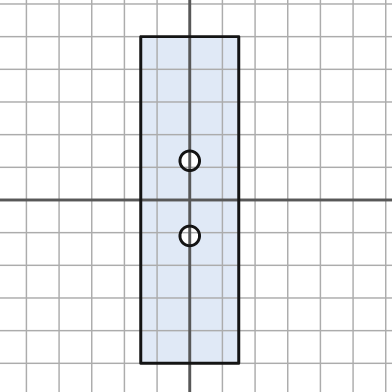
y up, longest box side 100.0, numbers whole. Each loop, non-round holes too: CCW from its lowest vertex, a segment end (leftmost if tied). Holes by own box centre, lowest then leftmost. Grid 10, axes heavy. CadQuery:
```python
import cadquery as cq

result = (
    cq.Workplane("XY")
    .moveTo(-15.0, -50.0)
    .lineTo(15.0, -50.0)
    .lineTo(15.0, 50.0)
    .lineTo(-15.0, 50.0)
    .close()
    .moveTo(0.0, -11.0)
    .circle(3.0)
    .moveTo(0.0, 12.0)
    .circle(3.0)
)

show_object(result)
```